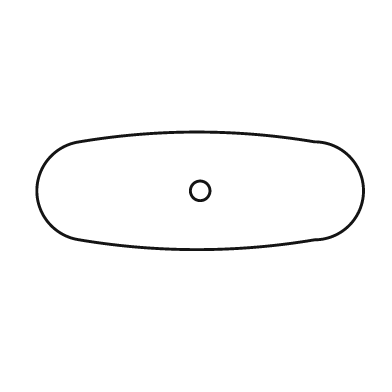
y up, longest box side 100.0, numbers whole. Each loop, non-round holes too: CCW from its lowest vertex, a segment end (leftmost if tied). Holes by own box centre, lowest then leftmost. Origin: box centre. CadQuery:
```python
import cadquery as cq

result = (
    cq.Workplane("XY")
    .moveTo(-37.0, -15.0)
    .threePointArc((-1.0, -18.0), (35.0, -15.0))
    .threePointArc((50.0, 0.0), (35.0, 15.0))
    .threePointArc((-1.0, 18.0), (-37.0, 15.0))
    .threePointArc((-50.0, 0.0), (-37.0, -15.0))
    .close()
    .moveTo(0.0, 0.0)
    .circle(3.0)
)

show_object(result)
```